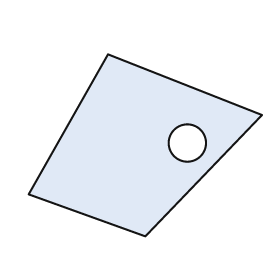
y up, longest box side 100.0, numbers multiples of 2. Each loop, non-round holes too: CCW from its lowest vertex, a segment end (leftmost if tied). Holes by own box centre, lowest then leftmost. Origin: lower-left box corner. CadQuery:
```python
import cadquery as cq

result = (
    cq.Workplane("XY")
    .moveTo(50.0, 0.0)
    .lineTo(100.0, 52.0)
    .lineTo(34.0, 78.0)
    .lineTo(0.0, 18.0)
    .close()
    .moveTo(68.0, 40.0)
    .circle(8.0)
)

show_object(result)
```